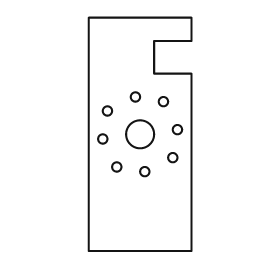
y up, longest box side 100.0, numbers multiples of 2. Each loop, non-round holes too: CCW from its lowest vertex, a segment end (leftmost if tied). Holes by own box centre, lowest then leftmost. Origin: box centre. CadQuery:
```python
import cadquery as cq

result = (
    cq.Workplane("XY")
    .moveTo(-22.0, -50.0)
    .lineTo(22.0, -50.0)
    .lineTo(22.0, 26.0)
    .lineTo(6.0, 26.0)
    .lineTo(6.0, 40.0)
    .lineTo(22.0, 40.0)
    .lineTo(22.0, 50.0)
    .lineTo(-22.0, 50.0)
    .close()
    .moveTo(2.0, -16.0)
    .circle(2.0)
    .moveTo(-10.0, -14.0)
    .circle(2.0)
    .moveTo(14.0, -10.0)
    .circle(2.0)
    .moveTo(-16.0, -2.0)
    .circle(2.0)
    .moveTo(0.0, 0.0)
    .circle(6.0)
    .moveTo(16.0, 2.0)
    .circle(2.0)
    .moveTo(-14.0, 10.0)
    .circle(2.0)
    .moveTo(10.0, 14.0)
    .circle(2.0)
    .moveTo(-2.0, 16.0)
    .circle(2.0)
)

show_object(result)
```